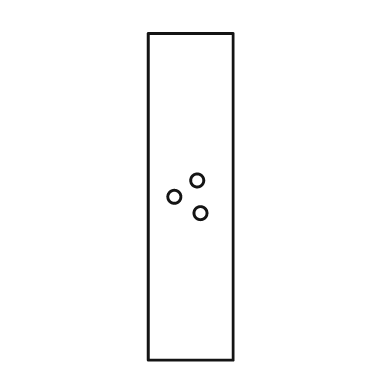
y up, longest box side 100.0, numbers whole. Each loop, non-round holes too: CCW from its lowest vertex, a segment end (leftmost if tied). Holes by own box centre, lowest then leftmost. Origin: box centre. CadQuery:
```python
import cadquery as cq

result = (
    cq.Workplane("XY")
    .moveTo(-13.0, -50.0)
    .lineTo(13.0, -50.0)
    .lineTo(13.0, 50.0)
    .lineTo(-13.0, 50.0)
    .close()
    .moveTo(3.0, -5.0)
    .circle(2.0)
    .moveTo(-5.0, 0.0)
    .circle(2.0)
    .moveTo(2.0, 5.0)
    .circle(2.0)
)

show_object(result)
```